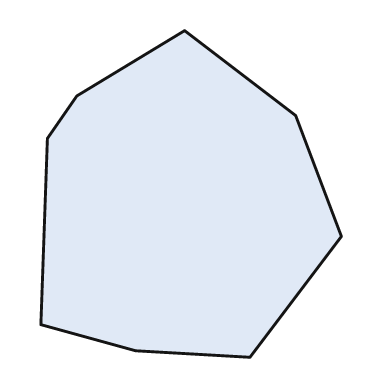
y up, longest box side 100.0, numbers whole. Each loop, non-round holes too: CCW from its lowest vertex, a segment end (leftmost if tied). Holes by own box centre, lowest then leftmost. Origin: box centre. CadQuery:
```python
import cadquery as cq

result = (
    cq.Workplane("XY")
    .moveTo(18.0, -50.0)
    .lineTo(46.0, -13.0)
    .lineTo(32.0, 24.0)
    .lineTo(-2.0, 50.0)
    .lineTo(-35.0, 30.0)
    .lineTo(-44.0, 17.0)
    .lineTo(-46.0, -40.0)
    .lineTo(-17.0, -48.0)
    .close()
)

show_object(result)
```